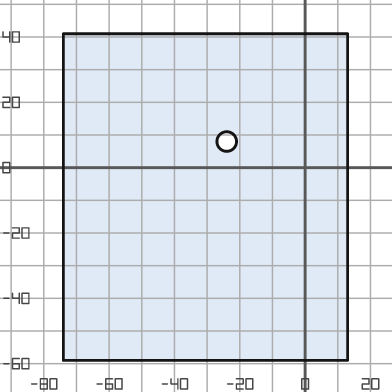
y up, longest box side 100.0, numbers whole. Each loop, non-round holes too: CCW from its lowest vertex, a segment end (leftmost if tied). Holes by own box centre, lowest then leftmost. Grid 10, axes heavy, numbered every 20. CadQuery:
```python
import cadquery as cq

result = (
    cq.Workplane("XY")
    .moveTo(-74.0, -59.0)
    .lineTo(13.0, -59.0)
    .lineTo(13.0, 41.0)
    .lineTo(-74.0, 41.0)
    .close()
    .moveTo(-24.0, 8.0)
    .circle(3.0)
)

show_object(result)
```